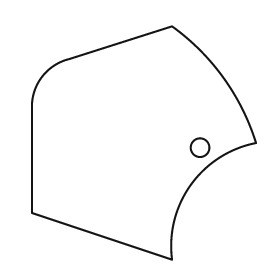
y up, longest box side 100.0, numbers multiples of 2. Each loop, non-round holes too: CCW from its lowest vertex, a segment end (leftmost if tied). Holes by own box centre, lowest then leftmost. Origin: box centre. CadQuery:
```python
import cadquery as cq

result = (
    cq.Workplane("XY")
    .moveTo(12.0, -50.0)
    .threePointArc((20.0, -18.0), (48.0, 0.0))
    .threePointArc((34.0, 28.0), (12.0, 50.0))
    .lineTo(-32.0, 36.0)
    .threePointArc((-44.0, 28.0), (-48.0, 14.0))
    .lineTo(-48.0, -30.0)
    .close()
    .moveTo(24.0, -2.0)
    .circle(4.0)
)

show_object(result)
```